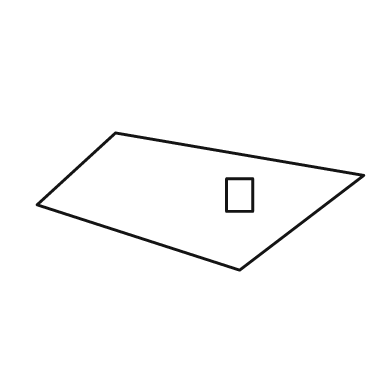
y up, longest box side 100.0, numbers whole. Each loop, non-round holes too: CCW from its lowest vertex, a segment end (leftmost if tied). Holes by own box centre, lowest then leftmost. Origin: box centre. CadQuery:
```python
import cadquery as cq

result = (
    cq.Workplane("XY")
    .moveTo(12.0, -21.0)
    .lineTo(50.0, 8.0)
    .lineTo(-26.0, 21.0)
    .lineTo(-50.0, -1.0)
    .close()
    .moveTo(8.0, -3.0)
    .lineTo(16.0, -3.0)
    .lineTo(16.0, 7.0)
    .lineTo(8.0, 7.0)
    .close()
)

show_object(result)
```